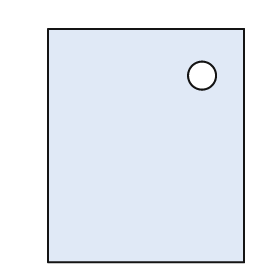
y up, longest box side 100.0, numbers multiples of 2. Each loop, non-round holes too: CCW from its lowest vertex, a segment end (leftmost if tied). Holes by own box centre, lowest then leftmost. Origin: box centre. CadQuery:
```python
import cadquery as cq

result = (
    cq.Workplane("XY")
    .moveTo(-42.0, -50.0)
    .lineTo(42.0, -50.0)
    .lineTo(42.0, 50.0)
    .lineTo(-42.0, 50.0)
    .close()
    .moveTo(24.0, 30.0)
    .circle(6.0)
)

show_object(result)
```